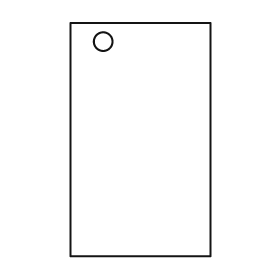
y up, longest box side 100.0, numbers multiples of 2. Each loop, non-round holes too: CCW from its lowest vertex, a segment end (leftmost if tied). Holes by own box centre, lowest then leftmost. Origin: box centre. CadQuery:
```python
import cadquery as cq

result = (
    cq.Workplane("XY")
    .moveTo(-30.0, -50.0)
    .lineTo(30.0, -50.0)
    .lineTo(30.0, 50.0)
    .lineTo(-30.0, 50.0)
    .close()
    .moveTo(-16.0, 42.0)
    .circle(4.0)
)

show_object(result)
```